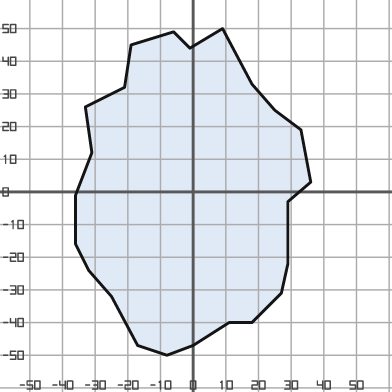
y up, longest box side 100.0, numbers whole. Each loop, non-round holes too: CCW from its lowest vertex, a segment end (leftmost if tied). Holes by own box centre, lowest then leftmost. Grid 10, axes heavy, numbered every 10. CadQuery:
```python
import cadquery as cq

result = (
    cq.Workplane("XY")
    .moveTo(-8.0, -50.0)
    .lineTo(0.0, -47.0)
    .lineTo(11.0, -40.0)
    .lineTo(18.0, -40.0)
    .lineTo(27.0, -31.0)
    .lineTo(29.0, -22.0)
    .lineTo(29.0, -3.0)
    .lineTo(36.0, 3.0)
    .lineTo(33.0, 19.0)
    .lineTo(25.0, 25.0)
    .lineTo(18.0, 33.0)
    .lineTo(9.0, 50.0)
    .lineTo(-1.0, 44.0)
    .lineTo(-6.0, 49.0)
    .lineTo(-19.0, 45.0)
    .lineTo(-21.0, 32.0)
    .lineTo(-33.0, 26.0)
    .lineTo(-31.0, 12.0)
    .lineTo(-36.0, -1.0)
    .lineTo(-36.0, -16.0)
    .lineTo(-32.0, -24.0)
    .lineTo(-25.0, -32.0)
    .lineTo(-17.0, -47.0)
    .close()
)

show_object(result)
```